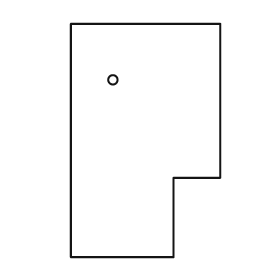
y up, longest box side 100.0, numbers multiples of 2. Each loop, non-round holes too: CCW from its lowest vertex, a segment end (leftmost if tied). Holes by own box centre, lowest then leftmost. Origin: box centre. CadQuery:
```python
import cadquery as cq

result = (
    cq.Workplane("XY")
    .moveTo(-32.0, -50.0)
    .lineTo(12.0, -50.0)
    .lineTo(12.0, -16.0)
    .lineTo(32.0, -16.0)
    .lineTo(32.0, 50.0)
    .lineTo(-32.0, 50.0)
    .close()
    .moveTo(-14.0, 26.0)
    .circle(2.0)
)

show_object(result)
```